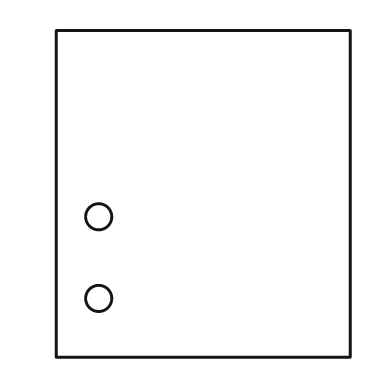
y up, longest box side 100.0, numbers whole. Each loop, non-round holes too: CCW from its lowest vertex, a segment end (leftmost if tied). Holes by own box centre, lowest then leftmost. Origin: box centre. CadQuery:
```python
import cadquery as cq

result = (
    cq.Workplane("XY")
    .moveTo(-45.0, -50.0)
    .lineTo(45.0, -50.0)
    .lineTo(45.0, 50.0)
    .lineTo(-45.0, 50.0)
    .close()
    .moveTo(-32.0, -32.0)
    .circle(4.0)
    .moveTo(-32.0, -7.0)
    .circle(4.0)
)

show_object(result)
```